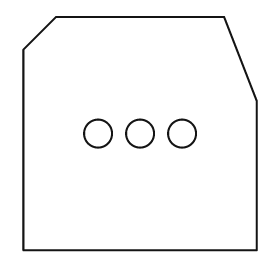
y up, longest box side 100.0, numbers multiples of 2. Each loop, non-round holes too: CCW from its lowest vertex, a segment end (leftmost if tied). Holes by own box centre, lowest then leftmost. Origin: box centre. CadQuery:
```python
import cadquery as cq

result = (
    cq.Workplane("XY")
    .moveTo(-50.0, -50.0)
    .lineTo(50.0, -50.0)
    .lineTo(50.0, 14.0)
    .lineTo(36.0, 50.0)
    .lineTo(-36.0, 50.0)
    .lineTo(-50.0, 36.0)
    .close()
    .moveTo(-18.0, 0.0)
    .circle(6.0)
    .moveTo(0.0, 0.0)
    .circle(6.0)
    .moveTo(18.0, 0.0)
    .circle(6.0)
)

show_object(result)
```